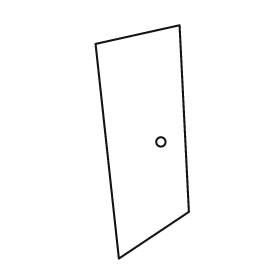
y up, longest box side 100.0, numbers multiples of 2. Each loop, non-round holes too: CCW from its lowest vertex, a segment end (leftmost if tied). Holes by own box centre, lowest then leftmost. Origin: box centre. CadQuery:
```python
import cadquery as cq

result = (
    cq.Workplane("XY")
    .moveTo(-10.0, -50.0)
    .lineTo(20.0, -30.0)
    .lineTo(16.0, 50.0)
    .lineTo(-20.0, 42.0)
    .close()
    .moveTo(8.0, 0.0)
    .circle(2.0)
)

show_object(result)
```